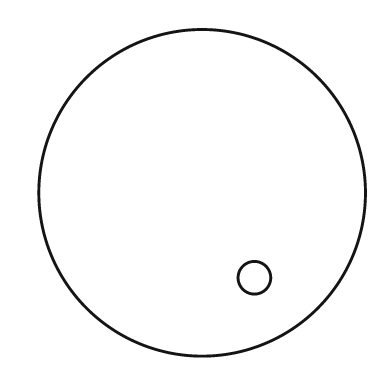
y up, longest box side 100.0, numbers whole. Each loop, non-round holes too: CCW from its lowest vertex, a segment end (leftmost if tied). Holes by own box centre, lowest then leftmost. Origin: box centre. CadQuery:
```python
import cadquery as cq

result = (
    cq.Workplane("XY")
    .moveTo(0.0, 0.0)
    .circle(50.0)
    .moveTo(16.0, -26.0)
    .circle(5.0)
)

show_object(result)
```